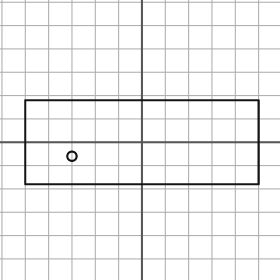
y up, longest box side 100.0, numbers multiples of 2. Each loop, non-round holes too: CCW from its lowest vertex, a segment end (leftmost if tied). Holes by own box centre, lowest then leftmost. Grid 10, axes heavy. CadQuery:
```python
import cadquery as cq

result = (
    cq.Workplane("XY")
    .moveTo(-50.0, -18.0)
    .lineTo(50.0, -18.0)
    .lineTo(50.0, 18.0)
    .lineTo(-50.0, 18.0)
    .close()
    .moveTo(-30.0, -6.0)
    .circle(2.0)
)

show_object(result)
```